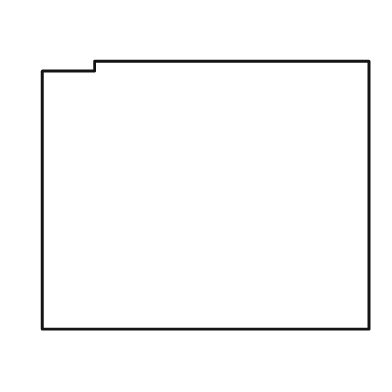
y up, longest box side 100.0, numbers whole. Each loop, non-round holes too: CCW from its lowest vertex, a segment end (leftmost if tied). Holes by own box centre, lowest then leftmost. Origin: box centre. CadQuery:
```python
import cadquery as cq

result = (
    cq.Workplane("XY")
    .moveTo(-50.0, -41.0)
    .lineTo(50.0, -41.0)
    .lineTo(50.0, 41.0)
    .lineTo(-34.0, 41.0)
    .lineTo(-34.0, 38.0)
    .lineTo(-50.0, 38.0)
    .close()
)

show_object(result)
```